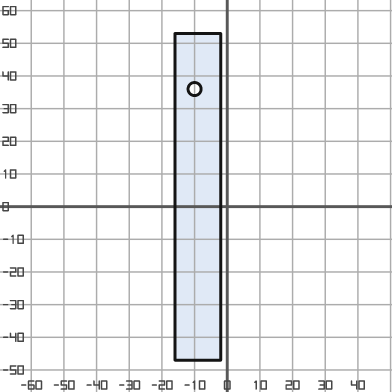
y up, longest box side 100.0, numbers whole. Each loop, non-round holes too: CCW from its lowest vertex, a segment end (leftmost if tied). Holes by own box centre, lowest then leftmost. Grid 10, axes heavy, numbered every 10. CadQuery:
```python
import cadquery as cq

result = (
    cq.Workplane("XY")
    .moveTo(-16.0, -47.0)
    .lineTo(-2.0, -47.0)
    .lineTo(-2.0, 53.0)
    .lineTo(-16.0, 53.0)
    .close()
    .moveTo(-10.0, 36.0)
    .circle(2.0)
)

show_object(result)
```